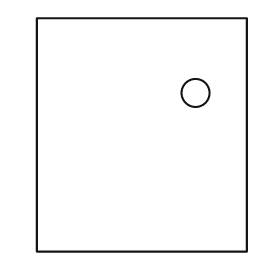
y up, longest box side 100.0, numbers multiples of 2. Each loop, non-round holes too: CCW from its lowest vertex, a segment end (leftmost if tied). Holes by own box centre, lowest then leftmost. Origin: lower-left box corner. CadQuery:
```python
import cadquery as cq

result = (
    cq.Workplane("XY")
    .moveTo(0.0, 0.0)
    .lineTo(90.0, 0.0)
    .lineTo(90.0, 100.0)
    .lineTo(0.0, 100.0)
    .close()
    .moveTo(68.0, 68.0)
    .circle(6.0)
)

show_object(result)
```